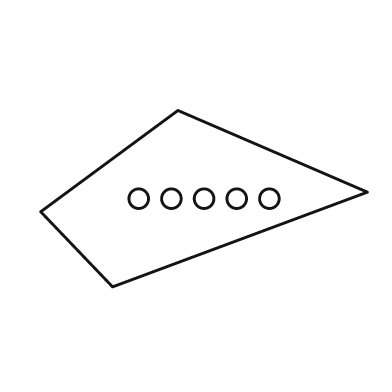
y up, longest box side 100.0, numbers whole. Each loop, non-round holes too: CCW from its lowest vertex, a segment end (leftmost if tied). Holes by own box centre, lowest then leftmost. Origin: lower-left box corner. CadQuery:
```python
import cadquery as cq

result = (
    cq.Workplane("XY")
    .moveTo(22.0, 0.0)
    .lineTo(100.0, 29.0)
    .lineTo(42.0, 54.0)
    .lineTo(0.0, 23.0)
    .close()
    .moveTo(30.0, 27.0)
    .circle(3.0)
    .moveTo(40.0, 27.0)
    .circle(3.0)
    .moveTo(50.0, 27.0)
    .circle(3.0)
    .moveTo(60.0, 27.0)
    .circle(3.0)
    .moveTo(70.0, 27.0)
    .circle(3.0)
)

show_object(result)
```